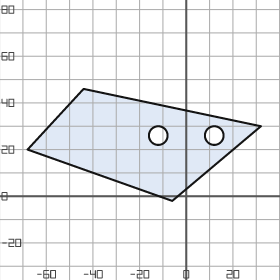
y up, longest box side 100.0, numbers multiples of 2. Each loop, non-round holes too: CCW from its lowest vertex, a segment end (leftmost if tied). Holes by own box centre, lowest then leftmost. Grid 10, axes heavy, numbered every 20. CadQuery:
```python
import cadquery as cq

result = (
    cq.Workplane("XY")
    .moveTo(-6.0, -2.0)
    .lineTo(32.0, 30.0)
    .lineTo(-44.0, 46.0)
    .lineTo(-68.0, 20.0)
    .close()
    .moveTo(-12.0, 26.0)
    .circle(4.0)
    .moveTo(12.0, 26.0)
    .circle(4.0)
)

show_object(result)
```